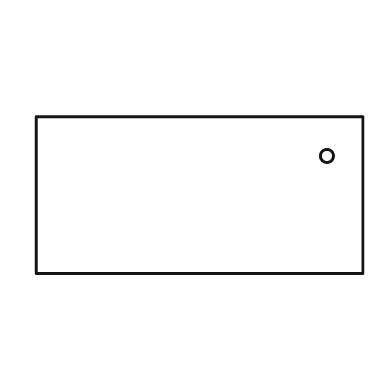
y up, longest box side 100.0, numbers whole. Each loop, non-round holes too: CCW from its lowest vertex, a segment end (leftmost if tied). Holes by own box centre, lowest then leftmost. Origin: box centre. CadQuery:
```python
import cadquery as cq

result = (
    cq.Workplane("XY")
    .moveTo(-50.0, -24.0)
    .lineTo(50.0, -24.0)
    .lineTo(50.0, 24.0)
    .lineTo(-50.0, 24.0)
    .close()
    .moveTo(39.0, 12.0)
    .circle(2.0)
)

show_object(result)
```